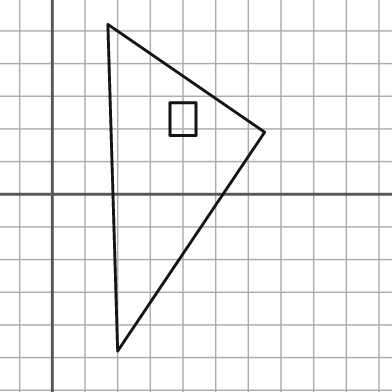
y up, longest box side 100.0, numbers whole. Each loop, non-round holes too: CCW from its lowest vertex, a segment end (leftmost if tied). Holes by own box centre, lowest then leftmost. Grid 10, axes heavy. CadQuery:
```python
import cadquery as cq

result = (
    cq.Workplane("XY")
    .moveTo(20.0, -48.0)
    .lineTo(65.0, 19.0)
    .lineTo(17.0, 52.0)
    .close()
    .moveTo(36.0, 18.0)
    .lineTo(44.0, 18.0)
    .lineTo(44.0, 28.0)
    .lineTo(36.0, 28.0)
    .close()
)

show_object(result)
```